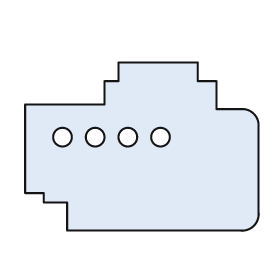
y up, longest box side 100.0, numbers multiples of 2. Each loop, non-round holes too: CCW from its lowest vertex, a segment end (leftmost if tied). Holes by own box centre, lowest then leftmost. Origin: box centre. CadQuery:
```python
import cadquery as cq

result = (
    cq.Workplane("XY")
    .moveTo(-32.0, -36.0)
    .lineTo(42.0, -36.0)
    .threePointArc((48.0, -34.0), (50.0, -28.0))
    .lineTo(50.0, 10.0)
    .threePointArc((48.0, 14.0), (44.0, 16.0))
    .lineTo(32.0, 16.0)
    .lineTo(32.0, 28.0)
    .lineTo(24.0, 28.0)
    .lineTo(24.0, 36.0)
    .lineTo(-10.0, 36.0)
    .lineTo(-10.0, 28.0)
    .lineTo(-16.0, 28.0)
    .lineTo(-16.0, 18.0)
    .lineTo(-50.0, 18.0)
    .lineTo(-50.0, -20.0)
    .lineTo(-42.0, -20.0)
    .lineTo(-42.0, -24.0)
    .lineTo(-32.0, -24.0)
    .close()
    .moveTo(-34.0, 4.0)
    .circle(4.0)
    .moveTo(-20.0, 4.0)
    .circle(4.0)
    .moveTo(-6.0, 4.0)
    .circle(4.0)
    .moveTo(8.0, 4.0)
    .circle(4.0)
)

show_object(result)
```